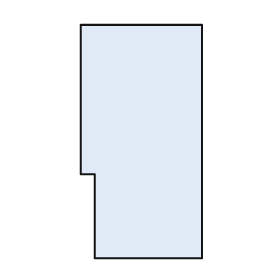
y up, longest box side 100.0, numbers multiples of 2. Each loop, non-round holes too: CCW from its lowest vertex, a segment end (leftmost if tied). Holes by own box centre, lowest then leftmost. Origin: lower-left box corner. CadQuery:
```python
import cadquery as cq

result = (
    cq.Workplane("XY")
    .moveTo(6.0, 0.0)
    .lineTo(52.0, 0.0)
    .lineTo(52.0, 100.0)
    .lineTo(0.0, 100.0)
    .lineTo(0.0, 36.0)
    .lineTo(6.0, 36.0)
    .close()
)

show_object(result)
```